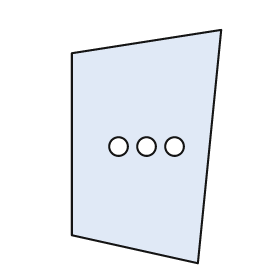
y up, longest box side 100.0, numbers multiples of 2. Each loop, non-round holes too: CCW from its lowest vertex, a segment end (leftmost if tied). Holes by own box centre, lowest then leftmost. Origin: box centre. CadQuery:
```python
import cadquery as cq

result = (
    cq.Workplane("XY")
    .moveTo(22.0, -50.0)
    .lineTo(32.0, 50.0)
    .lineTo(-32.0, 40.0)
    .lineTo(-32.0, -38.0)
    .close()
    .moveTo(-12.0, 0.0)
    .circle(4.0)
    .moveTo(0.0, 0.0)
    .circle(4.0)
    .moveTo(12.0, 0.0)
    .circle(4.0)
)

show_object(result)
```